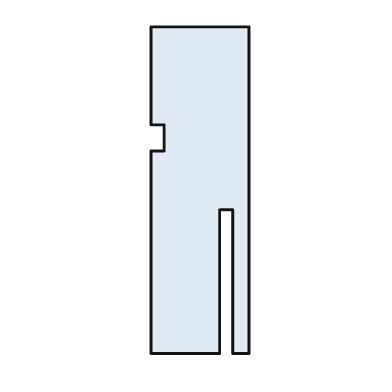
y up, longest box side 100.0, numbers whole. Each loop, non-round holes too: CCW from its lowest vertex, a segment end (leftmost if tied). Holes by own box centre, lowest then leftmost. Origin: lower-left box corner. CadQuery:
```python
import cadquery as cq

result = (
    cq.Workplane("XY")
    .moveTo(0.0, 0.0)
    .lineTo(21.0, 0.0)
    .lineTo(21.0, 44.0)
    .lineTo(25.0, 44.0)
    .lineTo(25.0, 0.0)
    .lineTo(30.0, 0.0)
    .lineTo(30.0, 100.0)
    .lineTo(0.0, 100.0)
    .lineTo(0.0, 70.0)
    .lineTo(4.0, 70.0)
    .lineTo(4.0, 62.0)
    .lineTo(0.0, 62.0)
    .close()
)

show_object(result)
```